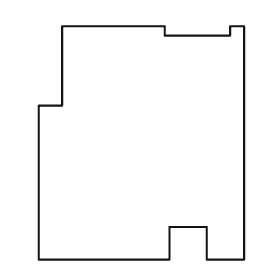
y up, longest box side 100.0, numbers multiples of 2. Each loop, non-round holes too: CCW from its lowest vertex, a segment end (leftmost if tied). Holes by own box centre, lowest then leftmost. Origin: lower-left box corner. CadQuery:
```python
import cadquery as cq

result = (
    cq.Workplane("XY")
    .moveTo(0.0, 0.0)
    .lineTo(56.0, 0.0)
    .lineTo(56.0, 14.0)
    .lineTo(72.0, 14.0)
    .lineTo(72.0, 0.0)
    .lineTo(88.0, 0.0)
    .lineTo(88.0, 100.0)
    .lineTo(82.0, 100.0)
    .lineTo(82.0, 96.0)
    .lineTo(54.0, 96.0)
    .lineTo(54.0, 100.0)
    .lineTo(10.0, 100.0)
    .lineTo(10.0, 66.0)
    .lineTo(0.0, 66.0)
    .close()
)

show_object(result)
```